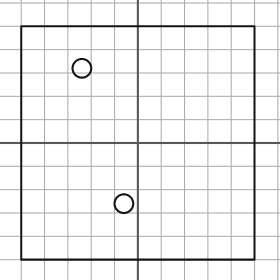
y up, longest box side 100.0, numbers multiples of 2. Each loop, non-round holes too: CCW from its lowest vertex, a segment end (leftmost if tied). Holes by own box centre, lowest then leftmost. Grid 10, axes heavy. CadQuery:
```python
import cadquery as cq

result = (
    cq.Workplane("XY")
    .moveTo(-50.0, -50.0)
    .lineTo(50.0, -50.0)
    .lineTo(50.0, 50.0)
    .lineTo(-50.0, 50.0)
    .close()
    .moveTo(-6.0, -26.0)
    .circle(4.0)
    .moveTo(-24.0, 32.0)
    .circle(4.0)
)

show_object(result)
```